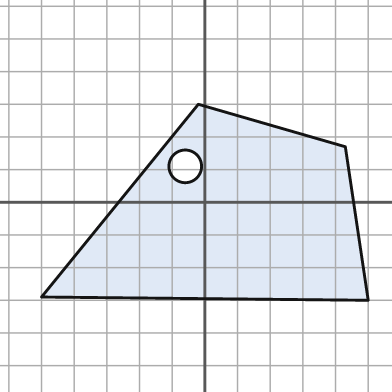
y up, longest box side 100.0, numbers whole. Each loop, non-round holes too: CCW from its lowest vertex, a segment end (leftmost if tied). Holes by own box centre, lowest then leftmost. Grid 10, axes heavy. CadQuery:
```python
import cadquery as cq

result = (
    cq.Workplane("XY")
    .moveTo(50.0, -30.0)
    .lineTo(43.0, 17.0)
    .lineTo(-2.0, 30.0)
    .lineTo(-50.0, -29.0)
    .close()
    .moveTo(-6.0, 11.0)
    .circle(5.0)
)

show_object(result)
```